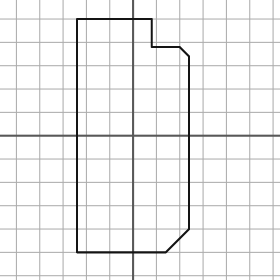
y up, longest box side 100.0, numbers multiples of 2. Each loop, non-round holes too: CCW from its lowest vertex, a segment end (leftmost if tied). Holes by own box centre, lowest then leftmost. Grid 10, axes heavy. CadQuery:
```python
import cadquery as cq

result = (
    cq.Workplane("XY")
    .moveTo(-24.0, -50.0)
    .lineTo(14.0, -50.0)
    .lineTo(24.0, -40.0)
    .lineTo(24.0, 34.0)
    .lineTo(20.0, 38.0)
    .lineTo(8.0, 38.0)
    .lineTo(8.0, 50.0)
    .lineTo(-24.0, 50.0)
    .close()
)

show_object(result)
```